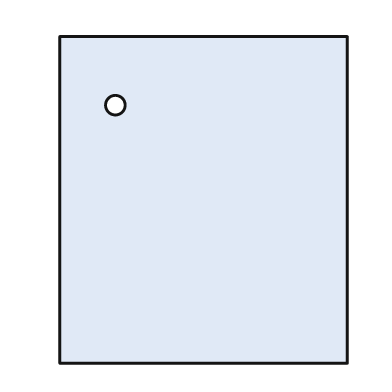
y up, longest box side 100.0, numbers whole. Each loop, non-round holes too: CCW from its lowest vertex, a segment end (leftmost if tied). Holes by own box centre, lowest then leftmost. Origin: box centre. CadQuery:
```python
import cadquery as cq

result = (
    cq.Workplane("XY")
    .moveTo(-44.0, -50.0)
    .lineTo(44.0, -50.0)
    .lineTo(44.0, 50.0)
    .lineTo(-44.0, 50.0)
    .close()
    .moveTo(-27.0, 29.0)
    .circle(3.0)
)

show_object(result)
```